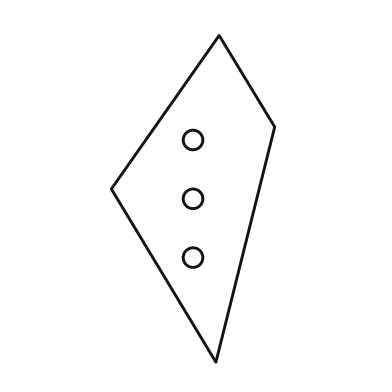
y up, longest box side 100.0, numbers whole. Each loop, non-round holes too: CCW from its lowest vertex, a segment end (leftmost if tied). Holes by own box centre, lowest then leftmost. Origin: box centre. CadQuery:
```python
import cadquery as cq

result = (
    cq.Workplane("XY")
    .moveTo(7.0, -50.0)
    .lineTo(25.0, 22.0)
    .lineTo(8.0, 50.0)
    .lineTo(-25.0, 3.0)
    .close()
    .moveTo(0.0, -18.0)
    .circle(3.0)
    .moveTo(0.0, 0.0)
    .circle(3.0)
    .moveTo(0.0, 18.0)
    .circle(3.0)
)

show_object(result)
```